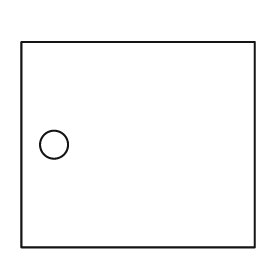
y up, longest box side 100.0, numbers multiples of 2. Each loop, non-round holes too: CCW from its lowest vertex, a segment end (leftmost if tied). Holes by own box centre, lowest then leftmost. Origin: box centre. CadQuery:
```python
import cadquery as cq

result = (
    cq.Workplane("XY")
    .moveTo(-50.0, -44.0)
    .lineTo(50.0, -44.0)
    .lineTo(50.0, 44.0)
    .lineTo(-50.0, 44.0)
    .close()
    .moveTo(-36.0, 0.0)
    .circle(6.0)
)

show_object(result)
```